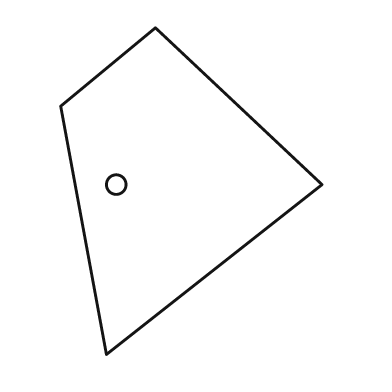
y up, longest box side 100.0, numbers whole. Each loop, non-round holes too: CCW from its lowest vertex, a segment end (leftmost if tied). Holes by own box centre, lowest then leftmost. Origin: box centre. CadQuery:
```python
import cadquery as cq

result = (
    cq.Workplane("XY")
    .moveTo(-26.0, -50.0)
    .lineTo(40.0, 2.0)
    .lineTo(-11.0, 50.0)
    .lineTo(-40.0, 26.0)
    .close()
    .moveTo(-23.0, 2.0)
    .circle(3.0)
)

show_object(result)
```